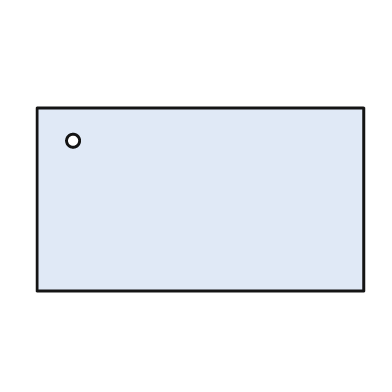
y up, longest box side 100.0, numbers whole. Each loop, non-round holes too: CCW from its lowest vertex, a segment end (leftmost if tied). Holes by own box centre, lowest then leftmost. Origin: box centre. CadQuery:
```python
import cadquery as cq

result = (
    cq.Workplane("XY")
    .moveTo(-50.0, -28.0)
    .lineTo(50.0, -28.0)
    .lineTo(50.0, 28.0)
    .lineTo(-50.0, 28.0)
    .close()
    .moveTo(-39.0, 18.0)
    .circle(2.0)
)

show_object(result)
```